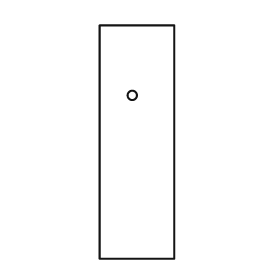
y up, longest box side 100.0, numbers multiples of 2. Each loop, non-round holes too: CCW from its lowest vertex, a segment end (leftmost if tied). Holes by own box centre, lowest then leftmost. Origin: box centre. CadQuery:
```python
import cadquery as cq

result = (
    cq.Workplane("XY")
    .moveTo(-16.0, -50.0)
    .lineTo(16.0, -50.0)
    .lineTo(16.0, 50.0)
    .lineTo(-16.0, 50.0)
    .close()
    .moveTo(-2.0, 20.0)
    .circle(2.0)
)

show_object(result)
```